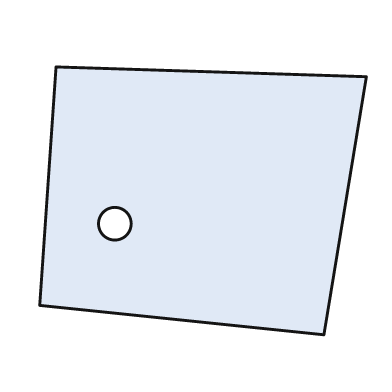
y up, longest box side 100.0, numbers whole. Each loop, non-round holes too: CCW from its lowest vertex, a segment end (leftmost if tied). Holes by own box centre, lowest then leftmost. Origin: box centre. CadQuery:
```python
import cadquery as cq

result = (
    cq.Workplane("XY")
    .moveTo(37.0, -41.0)
    .lineTo(50.0, 38.0)
    .lineTo(-45.0, 41.0)
    .lineTo(-50.0, -32.0)
    .close()
    .moveTo(-27.0, -7.0)
    .circle(5.0)
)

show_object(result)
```